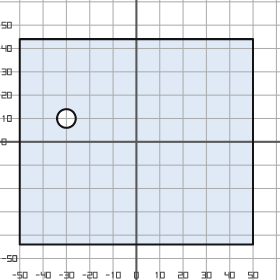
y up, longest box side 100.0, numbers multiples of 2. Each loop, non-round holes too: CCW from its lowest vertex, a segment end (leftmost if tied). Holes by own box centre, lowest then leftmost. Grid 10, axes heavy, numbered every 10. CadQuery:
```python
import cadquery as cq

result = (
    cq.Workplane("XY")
    .moveTo(-50.0, -44.0)
    .lineTo(50.0, -44.0)
    .lineTo(50.0, 44.0)
    .lineTo(-50.0, 44.0)
    .close()
    .moveTo(-30.0, 10.0)
    .circle(4.0)
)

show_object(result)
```